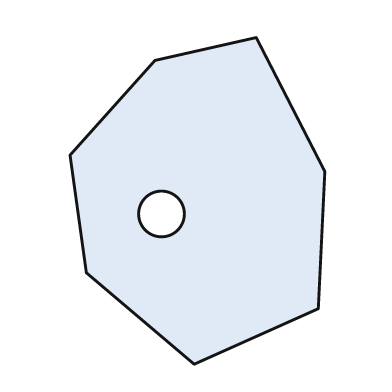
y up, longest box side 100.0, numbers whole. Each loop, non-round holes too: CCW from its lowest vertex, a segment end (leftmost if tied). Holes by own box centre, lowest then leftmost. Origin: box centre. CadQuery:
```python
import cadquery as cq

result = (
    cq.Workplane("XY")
    .moveTo(-1.0, -50.0)
    .lineTo(37.0, -33.0)
    .lineTo(39.0, 9.0)
    .lineTo(18.0, 50.0)
    .lineTo(-13.0, 43.0)
    .lineTo(-39.0, 14.0)
    .lineTo(-34.0, -22.0)
    .close()
    .moveTo(-11.0, -4.0)
    .circle(7.0)
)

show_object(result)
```